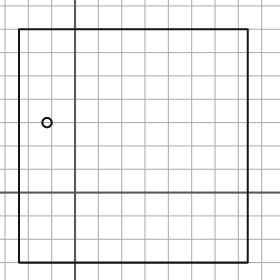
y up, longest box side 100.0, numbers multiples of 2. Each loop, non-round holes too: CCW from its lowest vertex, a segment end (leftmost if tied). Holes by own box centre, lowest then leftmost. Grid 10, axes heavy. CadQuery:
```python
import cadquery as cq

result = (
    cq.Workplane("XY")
    .moveTo(-24.0, -30.0)
    .lineTo(74.0, -30.0)
    .lineTo(74.0, 70.0)
    .lineTo(-24.0, 70.0)
    .close()
    .moveTo(-12.0, 30.0)
    .circle(2.0)
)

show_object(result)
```